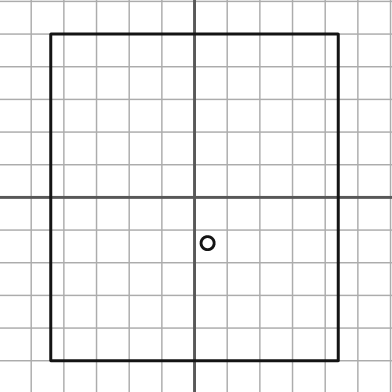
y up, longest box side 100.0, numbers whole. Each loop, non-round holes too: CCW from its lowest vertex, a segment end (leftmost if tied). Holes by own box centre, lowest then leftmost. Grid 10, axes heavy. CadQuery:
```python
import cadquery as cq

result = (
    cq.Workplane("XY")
    .moveTo(-44.0, -50.0)
    .lineTo(44.0, -50.0)
    .lineTo(44.0, 50.0)
    .lineTo(-44.0, 50.0)
    .close()
    .moveTo(4.0, -14.0)
    .circle(2.0)
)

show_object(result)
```